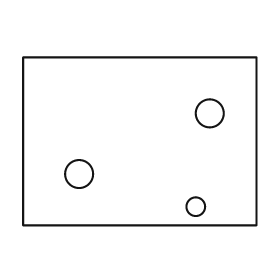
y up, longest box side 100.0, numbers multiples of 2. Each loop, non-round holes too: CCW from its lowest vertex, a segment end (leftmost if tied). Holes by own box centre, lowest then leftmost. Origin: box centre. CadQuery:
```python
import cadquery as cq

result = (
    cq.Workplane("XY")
    .moveTo(-50.0, -36.0)
    .lineTo(50.0, -36.0)
    .lineTo(50.0, 36.0)
    .lineTo(-50.0, 36.0)
    .close()
    .moveTo(24.0, -28.0)
    .circle(4.0)
    .moveTo(-26.0, -14.0)
    .circle(6.0)
    .moveTo(30.0, 12.0)
    .circle(6.0)
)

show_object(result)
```